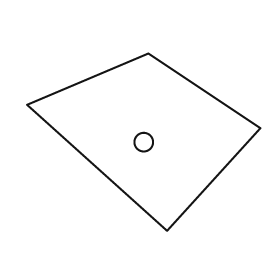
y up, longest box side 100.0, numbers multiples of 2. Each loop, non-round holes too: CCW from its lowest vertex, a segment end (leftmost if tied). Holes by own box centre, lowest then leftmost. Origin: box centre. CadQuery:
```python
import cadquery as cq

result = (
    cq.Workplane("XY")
    .moveTo(10.0, -38.0)
    .lineTo(50.0, 6.0)
    .lineTo(2.0, 38.0)
    .lineTo(-50.0, 16.0)
    .close()
    .moveTo(0.0, 0.0)
    .circle(4.0)
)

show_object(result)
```